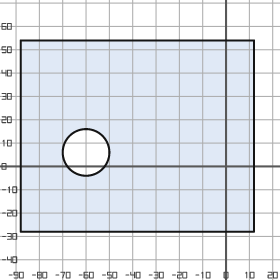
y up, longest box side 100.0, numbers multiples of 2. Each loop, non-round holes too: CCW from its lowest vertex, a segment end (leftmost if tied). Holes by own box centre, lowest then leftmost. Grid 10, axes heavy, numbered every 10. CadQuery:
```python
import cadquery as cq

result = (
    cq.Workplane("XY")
    .moveTo(-88.0, -28.0)
    .lineTo(12.0, -28.0)
    .lineTo(12.0, 54.0)
    .lineTo(-88.0, 54.0)
    .close()
    .moveTo(-60.0, 6.0)
    .circle(10.0)
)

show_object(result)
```